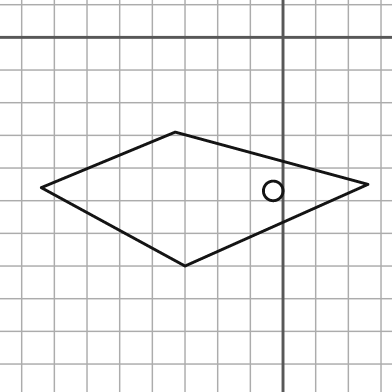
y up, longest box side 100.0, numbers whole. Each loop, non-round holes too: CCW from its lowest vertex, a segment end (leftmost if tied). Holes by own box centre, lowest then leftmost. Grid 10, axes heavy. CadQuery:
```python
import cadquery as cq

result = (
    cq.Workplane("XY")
    .moveTo(-30.0, -70.0)
    .lineTo(26.0, -45.0)
    .lineTo(-33.0, -29.0)
    .lineTo(-74.0, -46.0)
    .close()
    .moveTo(-3.0, -47.0)
    .circle(3.0)
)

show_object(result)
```